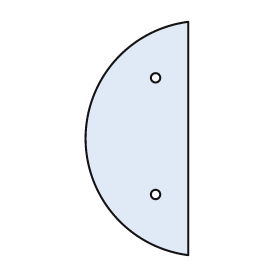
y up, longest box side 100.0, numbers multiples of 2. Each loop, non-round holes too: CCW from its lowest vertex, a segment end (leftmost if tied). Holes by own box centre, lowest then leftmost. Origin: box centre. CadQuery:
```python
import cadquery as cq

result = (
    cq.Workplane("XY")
    .moveTo(22.0, -50.0)
    .lineTo(22.0, 50.0)
    .threePointArc((-22.0, 0.0), (22.0, -50.0))
    .close()
    .moveTo(8.0, -24.0)
    .circle(2.0)
    .moveTo(8.0, 26.0)
    .circle(2.0)
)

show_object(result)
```